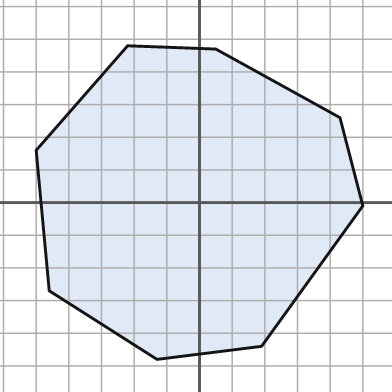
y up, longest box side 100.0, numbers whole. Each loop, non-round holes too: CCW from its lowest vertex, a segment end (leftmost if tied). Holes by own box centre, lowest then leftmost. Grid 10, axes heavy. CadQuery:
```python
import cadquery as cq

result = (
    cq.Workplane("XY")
    .moveTo(-13.0, -48.0)
    .lineTo(19.0, -44.0)
    .lineTo(50.0, -1.0)
    .lineTo(43.0, 26.0)
    .lineTo(5.0, 47.0)
    .lineTo(-22.0, 48.0)
    .lineTo(-50.0, 16.0)
    .lineTo(-46.0, -27.0)
    .close()
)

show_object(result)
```